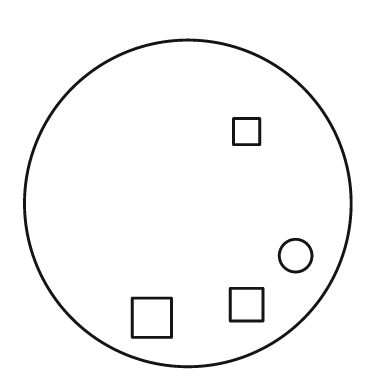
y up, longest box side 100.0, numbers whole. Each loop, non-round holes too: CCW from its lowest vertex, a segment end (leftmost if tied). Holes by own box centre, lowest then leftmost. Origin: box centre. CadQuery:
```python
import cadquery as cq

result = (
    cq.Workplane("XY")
    .moveTo(0.0, 0.0)
    .circle(50.0)
    .moveTo(-17.0, -41.0)
    .lineTo(-5.0, -41.0)
    .lineTo(-5.0, -29.0)
    .lineTo(-17.0, -29.0)
    .close()
    .moveTo(13.0, -36.0)
    .lineTo(23.0, -36.0)
    .lineTo(23.0, -26.0)
    .lineTo(13.0, -26.0)
    .close()
    .moveTo(33.0, -16.0)
    .circle(5.0)
    .moveTo(14.0, 18.0)
    .lineTo(22.0, 18.0)
    .lineTo(22.0, 26.0)
    .lineTo(14.0, 26.0)
    .close()
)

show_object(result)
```